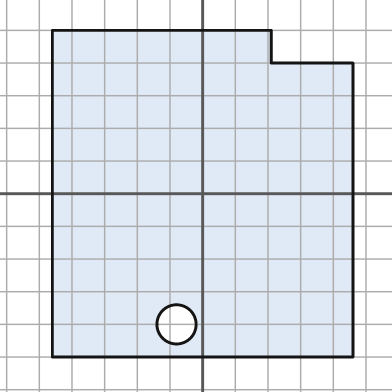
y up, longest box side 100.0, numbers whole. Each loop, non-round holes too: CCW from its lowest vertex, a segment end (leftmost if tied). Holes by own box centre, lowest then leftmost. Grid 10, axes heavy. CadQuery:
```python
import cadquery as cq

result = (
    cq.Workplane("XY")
    .moveTo(-46.0, -50.0)
    .lineTo(46.0, -50.0)
    .lineTo(46.0, 40.0)
    .lineTo(21.0, 40.0)
    .lineTo(21.0, 50.0)
    .lineTo(-46.0, 50.0)
    .close()
    .moveTo(-8.0, -40.0)
    .circle(6.0)
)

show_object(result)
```